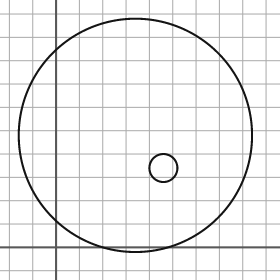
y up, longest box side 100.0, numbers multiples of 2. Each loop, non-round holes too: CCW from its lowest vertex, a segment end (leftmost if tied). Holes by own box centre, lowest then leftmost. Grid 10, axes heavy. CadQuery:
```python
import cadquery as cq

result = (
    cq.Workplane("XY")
    .moveTo(34.0, 48.0)
    .circle(50.0)
    .moveTo(46.0, 34.0)
    .circle(6.0)
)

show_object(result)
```